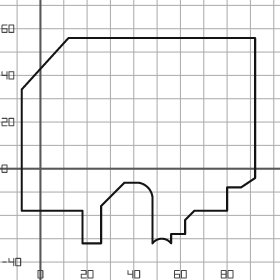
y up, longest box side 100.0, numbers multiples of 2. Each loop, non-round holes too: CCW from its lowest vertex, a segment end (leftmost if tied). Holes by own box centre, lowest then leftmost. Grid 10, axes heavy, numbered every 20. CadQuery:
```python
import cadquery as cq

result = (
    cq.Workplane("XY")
    .moveTo(18.0, -32.0)
    .lineTo(26.0, -32.0)
    .lineTo(26.0, -16.0)
    .lineTo(36.0, -6.0)
    .lineTo(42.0, -6.0)
    .threePointArc((46.0, -8.0), (48.0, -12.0))
    .lineTo(48.0, -32.0)
    .threePointArc((52.0, -30.0), (56.0, -32.0))
    .lineTo(56.0, -28.0)
    .lineTo(62.0, -28.0)
    .lineTo(62.0, -22.0)
    .lineTo(66.0, -18.0)
    .lineTo(80.0, -18.0)
    .lineTo(80.0, -8.0)
    .lineTo(86.0, -8.0)
    .lineTo(92.0, -4.0)
    .lineTo(92.0, 56.0)
    .lineTo(12.0, 56.0)
    .lineTo(-8.0, 34.0)
    .lineTo(-8.0, -18.0)
    .lineTo(18.0, -18.0)
    .close()
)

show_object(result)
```